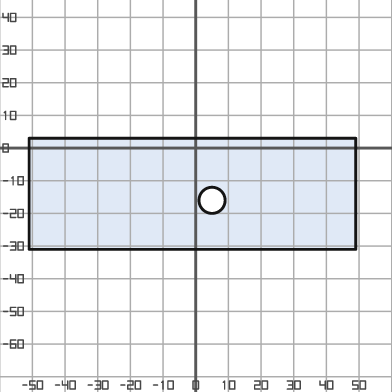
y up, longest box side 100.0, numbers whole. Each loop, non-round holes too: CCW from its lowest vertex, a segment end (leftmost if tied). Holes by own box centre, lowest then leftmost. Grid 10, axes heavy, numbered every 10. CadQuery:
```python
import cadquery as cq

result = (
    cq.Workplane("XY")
    .moveTo(-51.0, -31.0)
    .lineTo(49.0, -31.0)
    .lineTo(49.0, 3.0)
    .lineTo(-51.0, 3.0)
    .close()
    .moveTo(5.0, -16.0)
    .circle(4.0)
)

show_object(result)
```